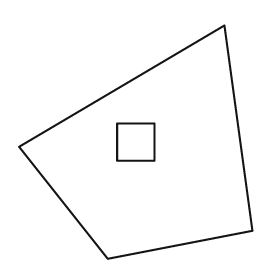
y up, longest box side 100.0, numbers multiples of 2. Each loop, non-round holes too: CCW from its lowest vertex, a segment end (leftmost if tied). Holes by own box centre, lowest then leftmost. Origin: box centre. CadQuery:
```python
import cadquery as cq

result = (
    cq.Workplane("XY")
    .moveTo(-12.0, -50.0)
    .lineTo(50.0, -38.0)
    .lineTo(38.0, 50.0)
    .lineTo(-50.0, -2.0)
    .close()
    .moveTo(-8.0, -8.0)
    .lineTo(8.0, -8.0)
    .lineTo(8.0, 8.0)
    .lineTo(-8.0, 8.0)
    .close()
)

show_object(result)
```